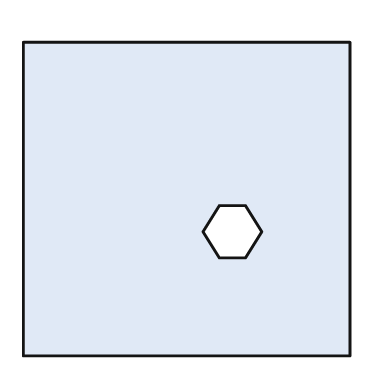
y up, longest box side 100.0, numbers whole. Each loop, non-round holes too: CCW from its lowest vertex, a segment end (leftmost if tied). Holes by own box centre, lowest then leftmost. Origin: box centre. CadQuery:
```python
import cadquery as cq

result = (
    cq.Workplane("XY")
    .moveTo(-50.0, -48.0)
    .lineTo(50.0, -48.0)
    .lineTo(50.0, 48.0)
    .lineTo(-50.0, 48.0)
    .close()
    .moveTo(10.0, -18.0)
    .lineTo(18.0, -18.0)
    .lineTo(23.0, -10.0)
    .lineTo(18.0, -2.0)
    .lineTo(10.0, -2.0)
    .lineTo(5.0, -10.0)
    .close()
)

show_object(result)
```